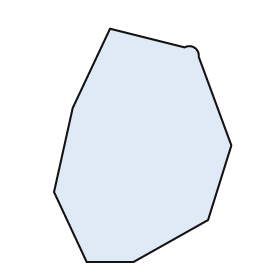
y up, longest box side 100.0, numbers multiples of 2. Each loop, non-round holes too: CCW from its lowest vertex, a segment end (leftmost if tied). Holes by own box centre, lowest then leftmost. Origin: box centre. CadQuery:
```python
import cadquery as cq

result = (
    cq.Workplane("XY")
    .moveTo(-24.0, -50.0)
    .lineTo(-4.0, -50.0)
    .lineTo(28.0, -32.0)
    .lineTo(38.0, 0.0)
    .lineTo(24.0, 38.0)
    .threePointArc((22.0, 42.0), (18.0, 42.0))
    .lineTo(-14.0, 50.0)
    .lineTo(-30.0, 16.0)
    .lineTo(-38.0, -20.0)
    .close()
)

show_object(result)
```